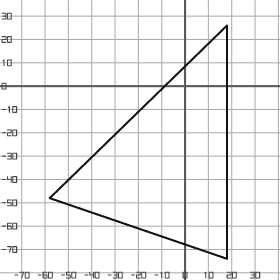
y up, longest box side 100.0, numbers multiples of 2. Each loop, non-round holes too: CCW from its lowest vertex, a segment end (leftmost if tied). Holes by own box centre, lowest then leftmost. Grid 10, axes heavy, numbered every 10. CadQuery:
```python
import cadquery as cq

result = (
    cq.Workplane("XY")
    .moveTo(18.0, -74.0)
    .lineTo(18.0, 26.0)
    .lineTo(-58.0, -48.0)
    .close()
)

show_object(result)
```